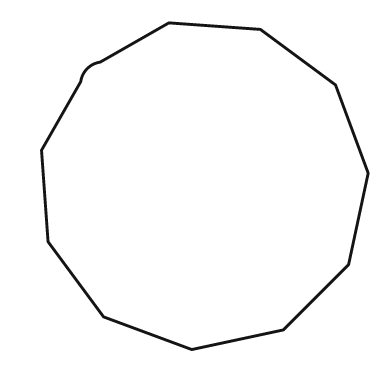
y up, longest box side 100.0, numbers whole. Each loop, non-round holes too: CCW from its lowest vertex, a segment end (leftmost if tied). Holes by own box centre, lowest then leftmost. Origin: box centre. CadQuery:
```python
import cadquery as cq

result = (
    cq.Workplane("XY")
    .moveTo(-4.0, -50.0)
    .lineTo(24.0, -44.0)
    .lineTo(44.0, -24.0)
    .lineTo(50.0, 4.0)
    .lineTo(40.0, 31.0)
    .lineTo(17.0, 48.0)
    .lineTo(-11.0, 50.0)
    .lineTo(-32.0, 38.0)
    .threePointArc((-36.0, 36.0), (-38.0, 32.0))
    .lineTo(-50.0, 11.0)
    .lineTo(-48.0, -17.0)
    .lineTo(-31.0, -40.0)
    .close()
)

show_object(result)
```